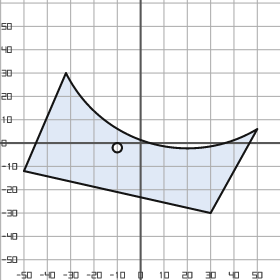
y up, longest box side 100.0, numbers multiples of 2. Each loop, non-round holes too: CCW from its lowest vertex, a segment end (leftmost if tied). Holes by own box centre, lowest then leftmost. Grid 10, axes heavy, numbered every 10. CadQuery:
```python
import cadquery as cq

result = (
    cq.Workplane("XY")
    .moveTo(30.0, -30.0)
    .lineTo(50.0, 6.0)
    .threePointArc((4.0, 0.0), (-32.0, 30.0))
    .lineTo(-50.0, -12.0)
    .close()
    .moveTo(-10.0, -2.0)
    .circle(2.0)
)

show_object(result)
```